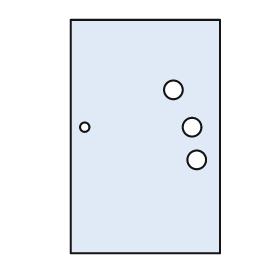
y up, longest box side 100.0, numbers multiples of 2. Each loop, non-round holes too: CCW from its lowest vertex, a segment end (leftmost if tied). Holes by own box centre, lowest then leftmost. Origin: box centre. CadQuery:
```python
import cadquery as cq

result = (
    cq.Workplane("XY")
    .moveTo(-32.0, -50.0)
    .lineTo(32.0, -50.0)
    .lineTo(32.0, 50.0)
    .lineTo(-32.0, 50.0)
    .close()
    .moveTo(22.0, -10.0)
    .circle(4.0)
    .moveTo(-26.0, 4.0)
    .circle(2.0)
    .moveTo(20.0, 4.0)
    .circle(4.0)
    .moveTo(12.0, 20.0)
    .circle(4.0)
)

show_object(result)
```